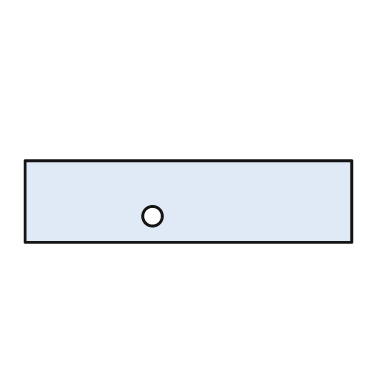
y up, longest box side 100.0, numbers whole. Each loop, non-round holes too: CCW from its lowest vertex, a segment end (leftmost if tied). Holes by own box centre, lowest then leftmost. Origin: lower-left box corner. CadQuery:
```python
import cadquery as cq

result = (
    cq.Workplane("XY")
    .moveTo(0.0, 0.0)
    .lineTo(100.0, 0.0)
    .lineTo(100.0, 25.0)
    .lineTo(0.0, 25.0)
    .close()
    .moveTo(39.0, 8.0)
    .circle(3.0)
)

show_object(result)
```